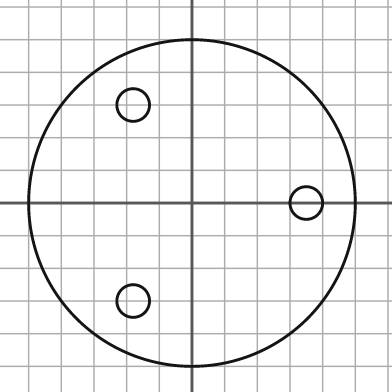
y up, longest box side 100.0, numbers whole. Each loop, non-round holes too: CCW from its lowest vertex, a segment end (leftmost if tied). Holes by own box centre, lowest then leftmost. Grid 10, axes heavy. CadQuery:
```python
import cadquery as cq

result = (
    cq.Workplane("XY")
    .moveTo(0.0, 0.0)
    .circle(50.0)
    .moveTo(-18.0, -30.0)
    .circle(5.0)
    .moveTo(35.0, 0.0)
    .circle(5.0)
    .moveTo(-18.0, 30.0)
    .circle(5.0)
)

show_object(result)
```